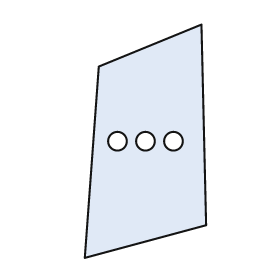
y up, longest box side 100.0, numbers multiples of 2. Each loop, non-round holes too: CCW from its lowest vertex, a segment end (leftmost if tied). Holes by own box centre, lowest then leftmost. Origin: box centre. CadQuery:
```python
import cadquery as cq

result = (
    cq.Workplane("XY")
    .moveTo(-26.0, -50.0)
    .lineTo(26.0, -36.0)
    .lineTo(24.0, 50.0)
    .lineTo(-20.0, 32.0)
    .close()
    .moveTo(-12.0, 0.0)
    .circle(4.0)
    .moveTo(0.0, 0.0)
    .circle(4.0)
    .moveTo(12.0, 0.0)
    .circle(4.0)
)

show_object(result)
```